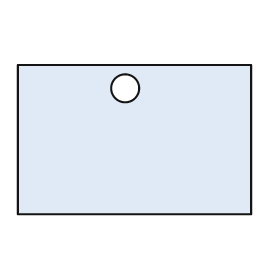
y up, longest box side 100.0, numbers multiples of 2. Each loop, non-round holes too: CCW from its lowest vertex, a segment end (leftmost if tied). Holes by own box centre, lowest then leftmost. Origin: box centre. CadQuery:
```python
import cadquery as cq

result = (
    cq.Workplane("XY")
    .moveTo(-50.0, -32.0)
    .lineTo(50.0, -32.0)
    .lineTo(50.0, 32.0)
    .lineTo(-50.0, 32.0)
    .close()
    .moveTo(-4.0, 22.0)
    .circle(6.0)
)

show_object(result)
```